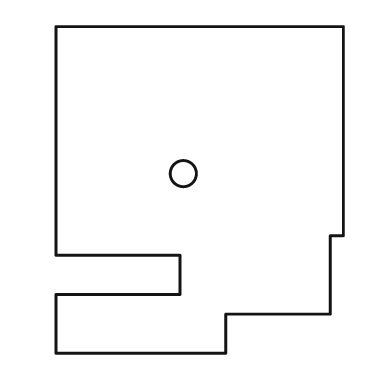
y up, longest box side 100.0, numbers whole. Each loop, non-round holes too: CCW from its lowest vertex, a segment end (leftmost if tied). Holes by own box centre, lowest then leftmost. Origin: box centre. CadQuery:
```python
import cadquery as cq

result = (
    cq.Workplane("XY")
    .moveTo(-44.0, -50.0)
    .lineTo(8.0, -50.0)
    .lineTo(8.0, -38.0)
    .lineTo(40.0, -38.0)
    .lineTo(40.0, -14.0)
    .lineTo(44.0, -14.0)
    .lineTo(44.0, 50.0)
    .lineTo(-44.0, 50.0)
    .lineTo(-44.0, -20.0)
    .lineTo(-6.0, -20.0)
    .lineTo(-6.0, -32.0)
    .lineTo(-44.0, -32.0)
    .close()
    .moveTo(-5.0, 5.0)
    .circle(4.0)
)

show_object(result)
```